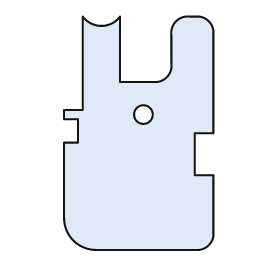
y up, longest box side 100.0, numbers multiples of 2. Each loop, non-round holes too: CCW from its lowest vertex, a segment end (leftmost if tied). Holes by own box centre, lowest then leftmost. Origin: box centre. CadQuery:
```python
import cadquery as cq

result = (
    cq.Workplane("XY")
    .moveTo(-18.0, -50.0)
    .lineTo(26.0, -50.0)
    .threePointArc((30.0, -48.0), (32.0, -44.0))
    .lineTo(32.0, -18.0)
    .lineTo(24.0, -18.0)
    .lineTo(24.0, 0.0)
    .lineTo(32.0, 0.0)
    .lineTo(32.0, 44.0)
    .threePointArc((30.0, 48.0), (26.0, 50.0))
    .lineTo(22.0, 50.0)
    .threePointArc((16.0, 48.0), (14.0, 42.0))
    .lineTo(14.0, 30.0)
    .threePointArc((12.0, 24.0), (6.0, 22.0))
    .lineTo(-8.0, 22.0)
    .lineTo(-8.0, 50.0)
    .threePointArc((-16.0, 46.0), (-24.0, 50.0))
    .lineTo(-24.0, 10.0)
    .lineTo(-32.0, 10.0)
    .lineTo(-32.0, 6.0)
    .lineTo(-26.0, 6.0)
    .lineTo(-26.0, -4.0)
    .lineTo(-32.0, -4.0)
    .lineTo(-32.0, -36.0)
    .threePointArc((-28.0, -46.0), (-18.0, -50.0))
    .close()
    .moveTo(2.0, 8.0)
    .circle(4.0)
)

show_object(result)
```